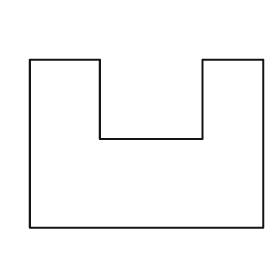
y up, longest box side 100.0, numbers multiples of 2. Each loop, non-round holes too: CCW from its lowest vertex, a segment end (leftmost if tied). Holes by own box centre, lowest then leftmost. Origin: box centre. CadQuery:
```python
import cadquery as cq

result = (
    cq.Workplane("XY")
    .moveTo(-50.0, -36.0)
    .lineTo(50.0, -36.0)
    .lineTo(50.0, 36.0)
    .lineTo(24.0, 36.0)
    .lineTo(24.0, 2.0)
    .lineTo(-20.0, 2.0)
    .lineTo(-20.0, 36.0)
    .lineTo(-50.0, 36.0)
    .close()
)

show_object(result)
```